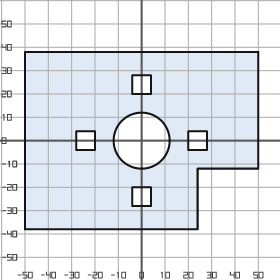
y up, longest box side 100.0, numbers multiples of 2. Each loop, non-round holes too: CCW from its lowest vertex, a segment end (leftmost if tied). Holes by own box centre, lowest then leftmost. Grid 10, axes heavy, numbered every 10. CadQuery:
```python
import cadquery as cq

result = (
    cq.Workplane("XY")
    .moveTo(-50.0, -38.0)
    .lineTo(24.0, -38.0)
    .lineTo(24.0, -12.0)
    .lineTo(50.0, -12.0)
    .lineTo(50.0, 38.0)
    .lineTo(-50.0, 38.0)
    .close()
    .moveTo(-4.0, -28.0)
    .lineTo(4.0, -28.0)
    .lineTo(4.0, -20.0)
    .lineTo(-4.0, -20.0)
    .close()
    .moveTo(-28.0, -4.0)
    .lineTo(-20.0, -4.0)
    .lineTo(-20.0, 4.0)
    .lineTo(-28.0, 4.0)
    .close()
    .moveTo(0.0, 0.0)
    .circle(12.0)
    .moveTo(20.0, -4.0)
    .lineTo(28.0, -4.0)
    .lineTo(28.0, 4.0)
    .lineTo(20.0, 4.0)
    .close()
    .moveTo(-4.0, 20.0)
    .lineTo(4.0, 20.0)
    .lineTo(4.0, 28.0)
    .lineTo(-4.0, 28.0)
    .close()
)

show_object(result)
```